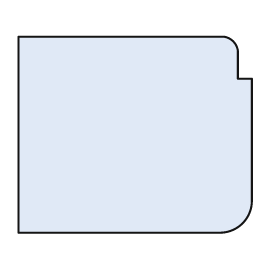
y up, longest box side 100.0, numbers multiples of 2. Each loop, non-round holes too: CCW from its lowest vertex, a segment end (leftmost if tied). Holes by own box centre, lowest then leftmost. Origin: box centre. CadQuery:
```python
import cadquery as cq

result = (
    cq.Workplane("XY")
    .moveTo(-50.0, -42.0)
    .lineTo(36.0, -42.0)
    .threePointArc((46.0, -38.0), (50.0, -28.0))
    .lineTo(50.0, 24.0)
    .lineTo(44.0, 24.0)
    .lineTo(44.0, 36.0)
    .threePointArc((42.0, 40.0), (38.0, 42.0))
    .lineTo(-50.0, 42.0)
    .close()
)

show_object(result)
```